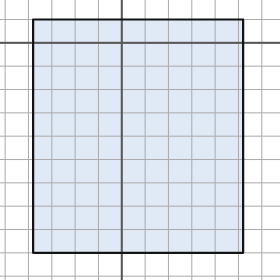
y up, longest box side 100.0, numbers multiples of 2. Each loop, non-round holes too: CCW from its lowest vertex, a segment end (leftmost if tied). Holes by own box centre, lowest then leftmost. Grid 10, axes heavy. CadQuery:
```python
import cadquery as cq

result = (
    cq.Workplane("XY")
    .moveTo(-38.0, -90.0)
    .lineTo(52.0, -90.0)
    .lineTo(52.0, 10.0)
    .lineTo(-38.0, 10.0)
    .close()
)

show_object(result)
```